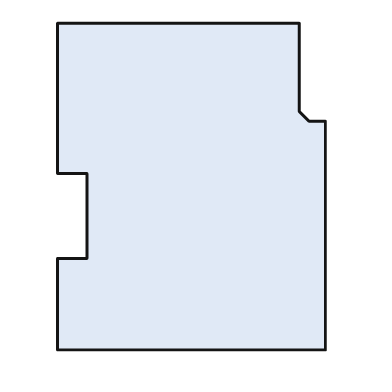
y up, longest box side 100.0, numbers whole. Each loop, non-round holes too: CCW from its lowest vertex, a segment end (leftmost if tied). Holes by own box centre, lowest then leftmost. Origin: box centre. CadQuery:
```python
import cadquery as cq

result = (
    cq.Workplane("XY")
    .moveTo(-41.0, -50.0)
    .lineTo(41.0, -50.0)
    .lineTo(41.0, 20.0)
    .lineTo(36.0, 20.0)
    .lineTo(33.0, 23.0)
    .lineTo(33.0, 50.0)
    .lineTo(-41.0, 50.0)
    .lineTo(-41.0, 4.0)
    .lineTo(-32.0, 4.0)
    .lineTo(-32.0, -22.0)
    .lineTo(-41.0, -22.0)
    .close()
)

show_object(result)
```